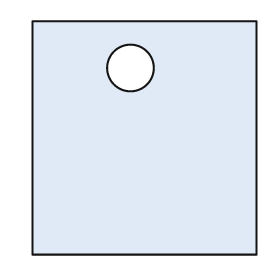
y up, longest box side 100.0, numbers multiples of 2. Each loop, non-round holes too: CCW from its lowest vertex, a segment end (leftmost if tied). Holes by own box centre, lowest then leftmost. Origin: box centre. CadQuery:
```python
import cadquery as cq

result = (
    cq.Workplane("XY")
    .moveTo(-48.0, -50.0)
    .lineTo(48.0, -50.0)
    .lineTo(48.0, 50.0)
    .lineTo(-48.0, 50.0)
    .close()
    .moveTo(-6.0, 30.0)
    .circle(10.0)
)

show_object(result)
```